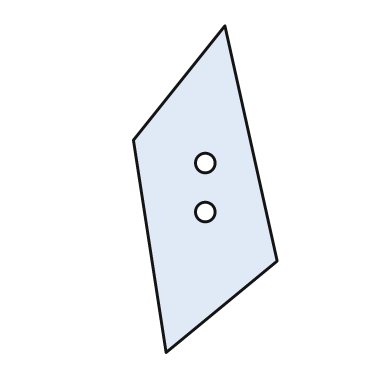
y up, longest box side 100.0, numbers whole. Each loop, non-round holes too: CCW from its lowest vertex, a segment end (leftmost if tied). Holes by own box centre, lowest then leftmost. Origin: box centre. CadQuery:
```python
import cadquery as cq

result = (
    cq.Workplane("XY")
    .moveTo(-12.0, -50.0)
    .lineTo(22.0, -22.0)
    .lineTo(6.0, 50.0)
    .lineTo(-22.0, 15.0)
    .close()
    .moveTo(0.0, -7.0)
    .circle(3.0)
    .moveTo(0.0, 8.0)
    .circle(3.0)
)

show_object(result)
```